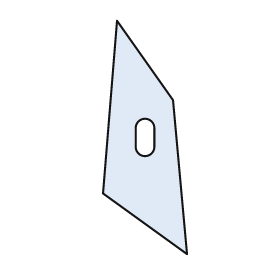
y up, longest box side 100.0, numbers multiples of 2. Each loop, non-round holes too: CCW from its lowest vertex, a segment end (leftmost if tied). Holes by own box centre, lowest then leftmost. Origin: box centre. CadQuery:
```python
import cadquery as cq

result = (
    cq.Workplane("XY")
    .moveTo(18.0, -50.0)
    .lineTo(12.0, 16.0)
    .lineTo(-12.0, 50.0)
    .lineTo(-18.0, -24.0)
    .close()
    .moveTo(-4.0, -4.0)
    .threePointArc((0.0, -8.0), (4.0, -4.0))
    .lineTo(4.0, 4.0)
    .threePointArc((0.0, 8.0), (-4.0, 4.0))
    .close()
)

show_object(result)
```